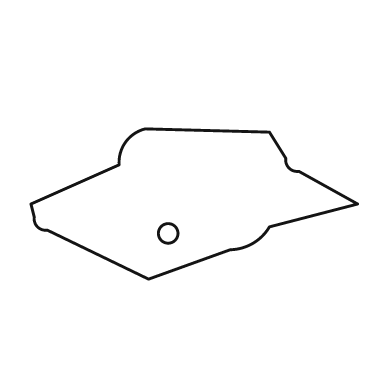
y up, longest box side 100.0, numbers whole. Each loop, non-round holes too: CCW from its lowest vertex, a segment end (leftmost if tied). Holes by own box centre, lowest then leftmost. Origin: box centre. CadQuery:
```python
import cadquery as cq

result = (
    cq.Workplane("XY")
    .moveTo(-14.0, -23.0)
    .lineTo(11.0, -14.0)
    .threePointArc((18.0, -12.0), (23.0, -7.0))
    .lineTo(50.0, 0.0)
    .lineTo(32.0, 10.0)
    .threePointArc((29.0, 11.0), (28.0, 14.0))
    .lineTo(23.0, 22.0)
    .lineTo(-15.0, 23.0)
    .threePointArc((-21.0, 19.0), (-23.0, 12.0))
    .lineTo(-50.0, 0.0)
    .lineTo(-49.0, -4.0)
    .threePointArc((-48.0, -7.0), (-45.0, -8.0))
    .close()
    .moveTo(-8.0, -9.0)
    .circle(3.0)
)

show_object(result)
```